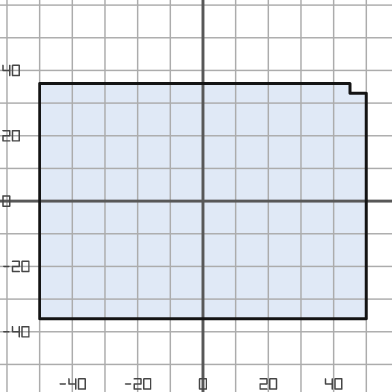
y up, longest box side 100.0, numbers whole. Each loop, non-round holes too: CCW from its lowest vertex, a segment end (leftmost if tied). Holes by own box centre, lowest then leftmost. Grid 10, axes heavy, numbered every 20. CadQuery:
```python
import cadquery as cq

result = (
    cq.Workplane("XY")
    .moveTo(-50.0, -36.0)
    .lineTo(50.0, -36.0)
    .lineTo(50.0, 33.0)
    .lineTo(45.0, 33.0)
    .lineTo(45.0, 36.0)
    .lineTo(-50.0, 36.0)
    .close()
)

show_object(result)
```